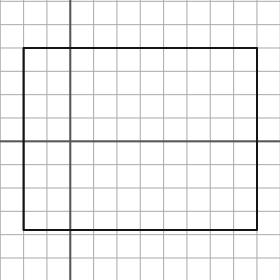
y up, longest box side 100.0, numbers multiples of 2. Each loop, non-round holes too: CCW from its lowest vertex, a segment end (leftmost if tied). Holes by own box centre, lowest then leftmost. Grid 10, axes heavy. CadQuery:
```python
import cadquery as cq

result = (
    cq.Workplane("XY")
    .moveTo(-20.0, -38.0)
    .lineTo(80.0, -38.0)
    .lineTo(80.0, 40.0)
    .lineTo(-20.0, 40.0)
    .close()
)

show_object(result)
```